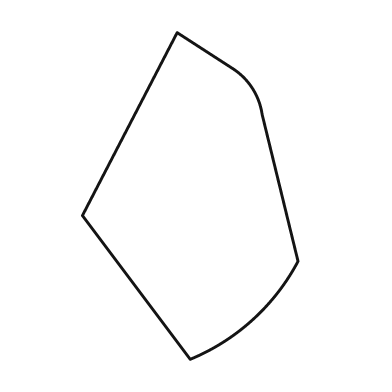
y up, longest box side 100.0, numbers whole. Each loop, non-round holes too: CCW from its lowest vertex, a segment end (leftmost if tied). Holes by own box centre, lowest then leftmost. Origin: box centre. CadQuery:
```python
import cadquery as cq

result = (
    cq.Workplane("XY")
    .moveTo(0.0, -50.0)
    .threePointArc((19.0, -38.0), (33.0, -20.0))
    .lineTo(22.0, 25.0)
    .threePointArc((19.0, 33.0), (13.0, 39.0))
    .lineTo(-4.0, 50.0)
    .lineTo(-33.0, -6.0)
    .close()
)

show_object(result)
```